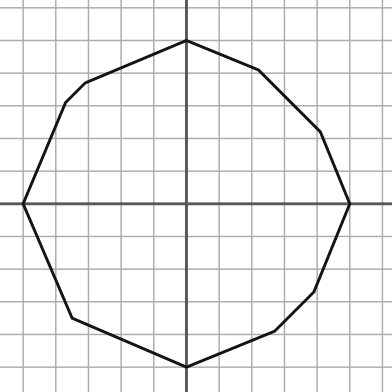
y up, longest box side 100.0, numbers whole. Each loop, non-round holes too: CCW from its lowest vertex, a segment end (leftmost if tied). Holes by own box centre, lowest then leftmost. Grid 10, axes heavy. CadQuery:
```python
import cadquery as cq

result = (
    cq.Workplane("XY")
    .moveTo(0.0, -50.0)
    .lineTo(27.0, -39.0)
    .lineTo(39.0, -27.0)
    .lineTo(50.0, 0.0)
    .lineTo(41.0, 22.0)
    .lineTo(22.0, 41.0)
    .lineTo(0.0, 50.0)
    .lineTo(-31.0, 37.0)
    .lineTo(-37.0, 31.0)
    .lineTo(-50.0, 0.0)
    .lineTo(-35.0, -35.0)
    .close()
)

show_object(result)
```